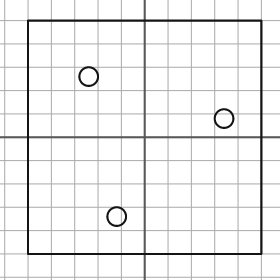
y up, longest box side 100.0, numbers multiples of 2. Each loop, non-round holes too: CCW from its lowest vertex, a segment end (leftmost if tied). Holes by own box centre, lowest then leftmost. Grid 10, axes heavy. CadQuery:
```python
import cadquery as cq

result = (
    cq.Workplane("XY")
    .moveTo(-50.0, -50.0)
    .lineTo(50.0, -50.0)
    .lineTo(50.0, 50.0)
    .lineTo(-50.0, 50.0)
    .close()
    .moveTo(-12.0, -34.0)
    .circle(4.0)
    .moveTo(34.0, 8.0)
    .circle(4.0)
    .moveTo(-24.0, 26.0)
    .circle(4.0)
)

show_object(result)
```